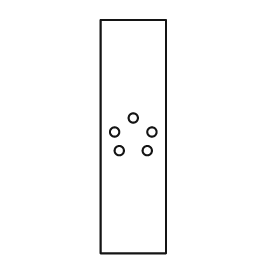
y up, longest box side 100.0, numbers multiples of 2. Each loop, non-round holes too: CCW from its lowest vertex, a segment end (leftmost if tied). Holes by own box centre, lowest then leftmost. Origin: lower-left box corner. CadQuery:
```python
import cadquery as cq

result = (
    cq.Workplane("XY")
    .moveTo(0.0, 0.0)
    .lineTo(28.0, 0.0)
    .lineTo(28.0, 100.0)
    .lineTo(0.0, 100.0)
    .close()
    .moveTo(8.0, 44.0)
    .circle(2.0)
    .moveTo(20.0, 44.0)
    .circle(2.0)
    .moveTo(6.0, 52.0)
    .circle(2.0)
    .moveTo(22.0, 52.0)
    .circle(2.0)
    .moveTo(14.0, 58.0)
    .circle(2.0)
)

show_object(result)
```